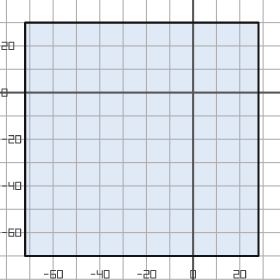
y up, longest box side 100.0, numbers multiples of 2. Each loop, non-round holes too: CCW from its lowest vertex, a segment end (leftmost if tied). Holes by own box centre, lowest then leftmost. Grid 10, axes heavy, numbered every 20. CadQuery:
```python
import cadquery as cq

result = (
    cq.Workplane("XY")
    .moveTo(-72.0, -70.0)
    .lineTo(28.0, -70.0)
    .lineTo(28.0, 30.0)
    .lineTo(-72.0, 30.0)
    .close()
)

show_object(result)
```